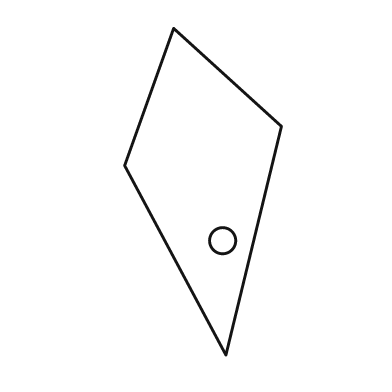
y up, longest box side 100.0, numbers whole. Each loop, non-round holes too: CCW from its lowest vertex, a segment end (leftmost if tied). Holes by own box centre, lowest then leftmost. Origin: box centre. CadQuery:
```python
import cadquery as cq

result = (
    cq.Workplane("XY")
    .moveTo(7.0, -50.0)
    .lineTo(24.0, 20.0)
    .lineTo(-9.0, 50.0)
    .lineTo(-24.0, 8.0)
    .close()
    .moveTo(6.0, -15.0)
    .circle(4.0)
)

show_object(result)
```